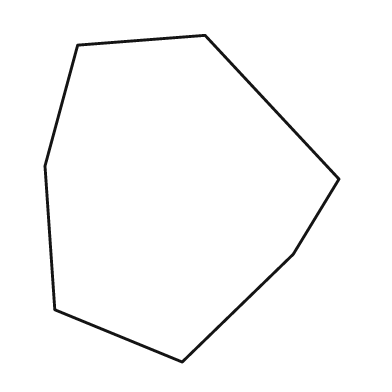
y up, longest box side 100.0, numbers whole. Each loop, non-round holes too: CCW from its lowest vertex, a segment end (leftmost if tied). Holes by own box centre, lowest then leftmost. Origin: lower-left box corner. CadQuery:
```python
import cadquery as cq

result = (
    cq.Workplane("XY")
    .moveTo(42.0, 0.0)
    .lineTo(76.0, 33.0)
    .lineTo(90.0, 56.0)
    .lineTo(49.0, 100.0)
    .lineTo(10.0, 97.0)
    .lineTo(0.0, 60.0)
    .lineTo(3.0, 16.0)
    .close()
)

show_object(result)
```